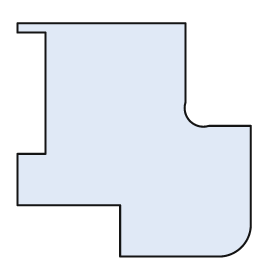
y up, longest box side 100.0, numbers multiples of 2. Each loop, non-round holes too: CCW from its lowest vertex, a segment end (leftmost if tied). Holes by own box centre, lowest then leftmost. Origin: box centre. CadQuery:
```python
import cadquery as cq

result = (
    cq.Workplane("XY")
    .moveTo(-6.0, -50.0)
    .lineTo(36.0, -50.0)
    .threePointArc((46.0, -46.0), (50.0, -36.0))
    .lineTo(50.0, 6.0)
    .lineTo(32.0, 6.0)
    .threePointArc((24.0, 8.0), (22.0, 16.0))
    .lineTo(22.0, 50.0)
    .lineTo(-50.0, 50.0)
    .lineTo(-50.0, 46.0)
    .lineTo(-38.0, 46.0)
    .lineTo(-38.0, -6.0)
    .lineTo(-50.0, -6.0)
    .lineTo(-50.0, -28.0)
    .lineTo(-6.0, -28.0)
    .close()
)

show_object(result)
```